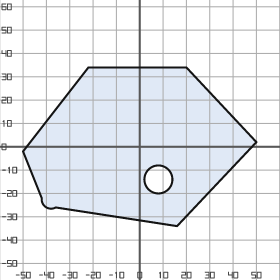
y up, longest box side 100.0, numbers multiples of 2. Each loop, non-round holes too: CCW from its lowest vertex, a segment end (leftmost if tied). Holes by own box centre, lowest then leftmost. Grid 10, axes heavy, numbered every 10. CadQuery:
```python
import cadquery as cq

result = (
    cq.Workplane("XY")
    .moveTo(16.0, -34.0)
    .lineTo(50.0, 2.0)
    .lineTo(20.0, 34.0)
    .lineTo(-22.0, 34.0)
    .lineTo(-50.0, -2.0)
    .lineTo(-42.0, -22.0)
    .threePointArc((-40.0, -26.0), (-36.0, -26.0))
    .close()
    .moveTo(8.0, -14.0)
    .circle(6.0)
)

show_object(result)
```